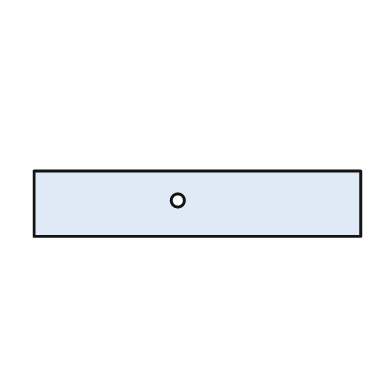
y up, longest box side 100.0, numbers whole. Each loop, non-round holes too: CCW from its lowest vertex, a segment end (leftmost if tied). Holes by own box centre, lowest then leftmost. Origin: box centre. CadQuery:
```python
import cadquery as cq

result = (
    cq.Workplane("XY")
    .moveTo(-50.0, -10.0)
    .lineTo(50.0, -10.0)
    .lineTo(50.0, 10.0)
    .lineTo(-50.0, 10.0)
    .close()
    .moveTo(-6.0, 1.0)
    .circle(2.0)
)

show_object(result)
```